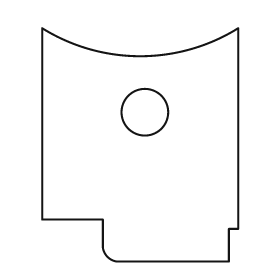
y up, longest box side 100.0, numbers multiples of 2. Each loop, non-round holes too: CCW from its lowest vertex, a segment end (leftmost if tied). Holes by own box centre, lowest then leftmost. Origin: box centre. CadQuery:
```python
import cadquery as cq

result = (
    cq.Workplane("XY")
    .moveTo(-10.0, -50.0)
    .lineTo(38.0, -50.0)
    .lineTo(38.0, -36.0)
    .lineTo(42.0, -36.0)
    .lineTo(42.0, 50.0)
    .threePointArc((0.0, 38.0), (-42.0, 50.0))
    .lineTo(-42.0, -32.0)
    .lineTo(-16.0, -32.0)
    .lineTo(-16.0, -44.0)
    .threePointArc((-14.0, -48.0), (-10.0, -50.0))
    .close()
    .moveTo(2.0, 14.0)
    .circle(10.0)
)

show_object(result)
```